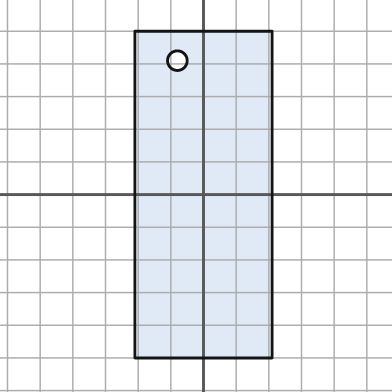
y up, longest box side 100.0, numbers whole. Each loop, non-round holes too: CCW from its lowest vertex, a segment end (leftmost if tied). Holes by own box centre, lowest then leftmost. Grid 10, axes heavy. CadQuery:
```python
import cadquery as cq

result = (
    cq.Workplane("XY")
    .moveTo(-21.0, -50.0)
    .lineTo(21.0, -50.0)
    .lineTo(21.0, 50.0)
    .lineTo(-21.0, 50.0)
    .close()
    .moveTo(-8.0, 41.0)
    .circle(3.0)
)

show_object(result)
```